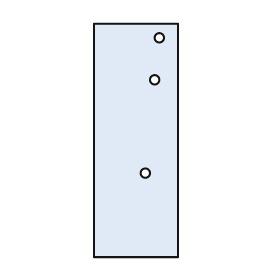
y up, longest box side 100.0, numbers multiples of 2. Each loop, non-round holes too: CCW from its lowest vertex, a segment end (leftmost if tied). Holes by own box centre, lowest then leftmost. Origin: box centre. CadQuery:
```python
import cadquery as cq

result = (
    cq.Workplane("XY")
    .moveTo(-18.0, -50.0)
    .lineTo(18.0, -50.0)
    .lineTo(18.0, 50.0)
    .lineTo(-18.0, 50.0)
    .close()
    .moveTo(4.0, -14.0)
    .circle(2.0)
    .moveTo(8.0, 26.0)
    .circle(2.0)
    .moveTo(10.0, 44.0)
    .circle(2.0)
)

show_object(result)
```